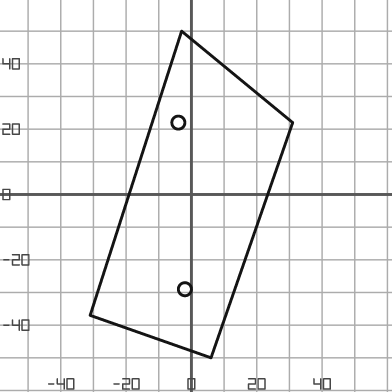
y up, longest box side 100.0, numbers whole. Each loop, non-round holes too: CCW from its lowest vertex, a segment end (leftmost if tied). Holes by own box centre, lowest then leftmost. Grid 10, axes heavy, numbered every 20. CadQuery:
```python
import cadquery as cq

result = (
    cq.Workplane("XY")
    .moveTo(6.0, -50.0)
    .lineTo(31.0, 22.0)
    .lineTo(-3.0, 50.0)
    .lineTo(-31.0, -37.0)
    .close()
    .moveTo(-2.0, -29.0)
    .circle(2.0)
    .moveTo(-4.0, 22.0)
    .circle(2.0)
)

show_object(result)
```